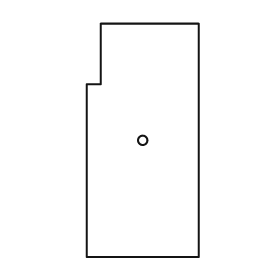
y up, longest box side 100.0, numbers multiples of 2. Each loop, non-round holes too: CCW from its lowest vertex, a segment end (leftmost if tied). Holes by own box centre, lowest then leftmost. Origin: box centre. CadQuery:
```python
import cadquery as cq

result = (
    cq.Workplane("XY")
    .moveTo(-24.0, -50.0)
    .lineTo(24.0, -50.0)
    .lineTo(24.0, 50.0)
    .lineTo(-18.0, 50.0)
    .lineTo(-18.0, 24.0)
    .lineTo(-24.0, 24.0)
    .close()
    .moveTo(0.0, 0.0)
    .circle(2.0)
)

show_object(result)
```